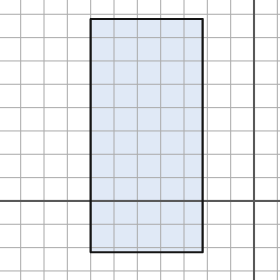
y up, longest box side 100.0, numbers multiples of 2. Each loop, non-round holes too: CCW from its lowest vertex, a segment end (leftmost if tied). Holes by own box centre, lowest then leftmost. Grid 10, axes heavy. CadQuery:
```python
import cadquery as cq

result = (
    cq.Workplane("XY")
    .moveTo(-70.0, -22.0)
    .lineTo(-22.0, -22.0)
    .lineTo(-22.0, 78.0)
    .lineTo(-70.0, 78.0)
    .close()
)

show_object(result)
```